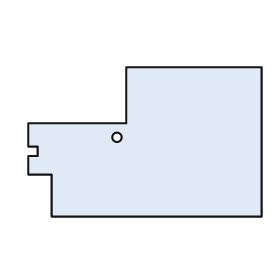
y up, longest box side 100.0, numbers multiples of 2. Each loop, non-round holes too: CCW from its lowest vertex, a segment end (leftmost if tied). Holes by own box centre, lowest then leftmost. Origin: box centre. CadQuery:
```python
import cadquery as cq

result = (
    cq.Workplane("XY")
    .moveTo(-40.0, -32.0)
    .lineTo(50.0, -32.0)
    .lineTo(50.0, 32.0)
    .lineTo(-8.0, 32.0)
    .lineTo(-8.0, 8.0)
    .lineTo(-50.0, 8.0)
    .lineTo(-50.0, -2.0)
    .lineTo(-46.0, -2.0)
    .lineTo(-46.0, -6.0)
    .lineTo(-50.0, -6.0)
    .lineTo(-50.0, -14.0)
    .lineTo(-40.0, -14.0)
    .close()
    .moveTo(-12.0, 2.0)
    .circle(2.0)
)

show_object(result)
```